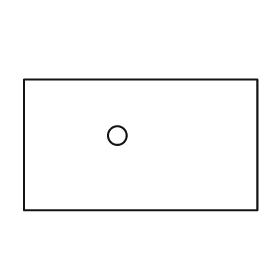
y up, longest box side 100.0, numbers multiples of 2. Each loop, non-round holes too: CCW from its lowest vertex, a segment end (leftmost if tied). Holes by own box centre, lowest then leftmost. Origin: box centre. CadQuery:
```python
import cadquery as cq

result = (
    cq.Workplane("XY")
    .moveTo(-50.0, -28.0)
    .lineTo(50.0, -28.0)
    .lineTo(50.0, 28.0)
    .lineTo(-50.0, 28.0)
    .close()
    .moveTo(-10.0, 4.0)
    .circle(4.0)
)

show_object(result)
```